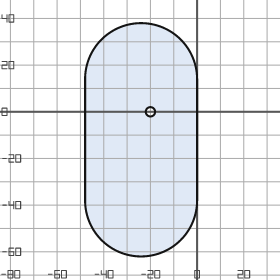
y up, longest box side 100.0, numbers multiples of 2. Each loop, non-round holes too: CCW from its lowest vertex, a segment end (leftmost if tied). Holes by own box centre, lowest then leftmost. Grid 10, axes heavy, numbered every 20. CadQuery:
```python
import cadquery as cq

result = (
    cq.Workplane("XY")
    .moveTo(-48.0, -38.0)
    .threePointArc((-24.0, -62.0), (0.0, -38.0))
    .lineTo(0.0, 14.0)
    .threePointArc((-24.0, 38.0), (-48.0, 14.0))
    .close()
    .moveTo(-20.0, 0.0)
    .circle(2.0)
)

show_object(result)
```